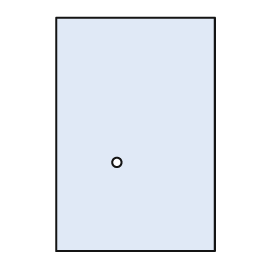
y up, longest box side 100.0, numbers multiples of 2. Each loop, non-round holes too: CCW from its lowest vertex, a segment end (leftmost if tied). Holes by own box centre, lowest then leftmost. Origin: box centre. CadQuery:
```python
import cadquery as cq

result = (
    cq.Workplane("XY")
    .moveTo(-34.0, -50.0)
    .lineTo(34.0, -50.0)
    .lineTo(34.0, 50.0)
    .lineTo(-34.0, 50.0)
    .close()
    .moveTo(-8.0, -12.0)
    .circle(2.0)
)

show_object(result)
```